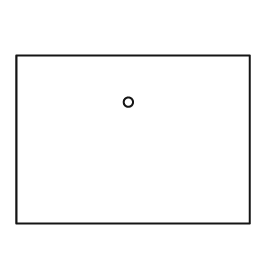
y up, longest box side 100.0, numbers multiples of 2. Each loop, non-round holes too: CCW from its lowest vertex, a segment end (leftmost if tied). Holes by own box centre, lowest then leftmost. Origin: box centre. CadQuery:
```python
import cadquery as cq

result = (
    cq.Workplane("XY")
    .moveTo(-50.0, -36.0)
    .lineTo(50.0, -36.0)
    .lineTo(50.0, 36.0)
    .lineTo(-50.0, 36.0)
    .close()
    .moveTo(-2.0, 16.0)
    .circle(2.0)
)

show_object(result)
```